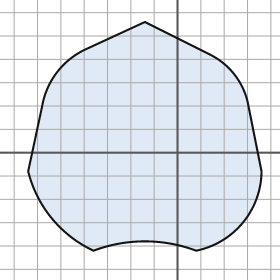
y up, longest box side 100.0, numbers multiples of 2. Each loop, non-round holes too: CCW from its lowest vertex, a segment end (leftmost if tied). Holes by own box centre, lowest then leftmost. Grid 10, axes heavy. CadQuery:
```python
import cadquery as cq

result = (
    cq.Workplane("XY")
    .moveTo(-36.0, -42.0)
    .threePointArc((-14.0, -38.0), (8.0, -42.0))
    .threePointArc((28.0, -30.0), (36.0, -8.0))
    .lineTo(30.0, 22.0)
    .threePointArc((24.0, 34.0), (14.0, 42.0))
    .lineTo(-14.0, 56.0)
    .lineTo(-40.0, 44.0)
    .threePointArc((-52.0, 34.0), (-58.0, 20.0))
    .lineTo(-64.0, -8.0)
    .threePointArc((-54.0, -28.0), (-36.0, -42.0))
    .close()
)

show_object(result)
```